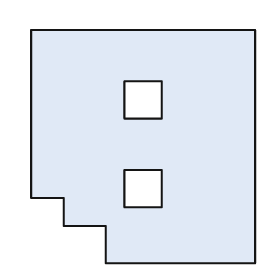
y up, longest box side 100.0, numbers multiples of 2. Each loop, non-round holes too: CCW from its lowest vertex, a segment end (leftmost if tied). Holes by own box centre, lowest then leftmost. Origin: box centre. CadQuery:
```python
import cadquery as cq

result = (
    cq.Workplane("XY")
    .moveTo(-16.0, -50.0)
    .lineTo(48.0, -50.0)
    .lineTo(48.0, 50.0)
    .lineTo(-48.0, 50.0)
    .lineTo(-48.0, -22.0)
    .lineTo(-34.0, -22.0)
    .lineTo(-34.0, -34.0)
    .lineTo(-16.0, -34.0)
    .close()
    .moveTo(-8.0, -26.0)
    .lineTo(8.0, -26.0)
    .lineTo(8.0, -10.0)
    .lineTo(-8.0, -10.0)
    .close()
    .moveTo(-8.0, 12.0)
    .lineTo(8.0, 12.0)
    .lineTo(8.0, 28.0)
    .lineTo(-8.0, 28.0)
    .close()
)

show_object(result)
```